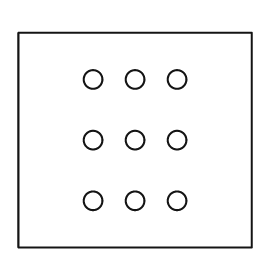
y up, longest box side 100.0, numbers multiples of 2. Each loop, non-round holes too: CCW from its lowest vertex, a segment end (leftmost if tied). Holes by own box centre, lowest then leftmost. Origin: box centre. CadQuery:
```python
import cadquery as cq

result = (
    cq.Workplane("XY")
    .moveTo(-50.0, -46.0)
    .lineTo(50.0, -46.0)
    .lineTo(50.0, 46.0)
    .lineTo(-50.0, 46.0)
    .close()
    .moveTo(-18.0, -26.0)
    .circle(4.0)
    .moveTo(0.0, -26.0)
    .circle(4.0)
    .moveTo(18.0, -26.0)
    .circle(4.0)
    .moveTo(-18.0, 0.0)
    .circle(4.0)
    .moveTo(0.0, 0.0)
    .circle(4.0)
    .moveTo(18.0, 0.0)
    .circle(4.0)
    .moveTo(-18.0, 26.0)
    .circle(4.0)
    .moveTo(0.0, 26.0)
    .circle(4.0)
    .moveTo(18.0, 26.0)
    .circle(4.0)
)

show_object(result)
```